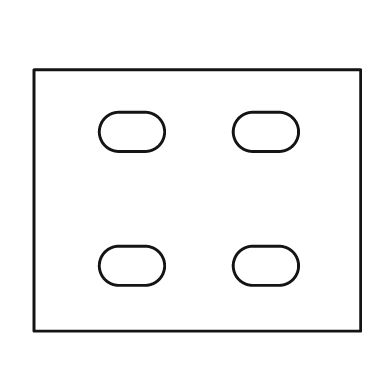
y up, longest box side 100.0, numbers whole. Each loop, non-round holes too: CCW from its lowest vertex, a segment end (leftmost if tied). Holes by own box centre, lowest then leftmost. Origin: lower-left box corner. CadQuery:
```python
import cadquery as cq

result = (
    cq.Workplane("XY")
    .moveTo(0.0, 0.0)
    .lineTo(100.0, 0.0)
    .lineTo(100.0, 80.0)
    .lineTo(0.0, 80.0)
    .close()
    .moveTo(26.0, 14.0)
    .lineTo(34.0, 14.0)
    .threePointArc((40.0, 20.0), (34.0, 26.0))
    .lineTo(26.0, 26.0)
    .threePointArc((20.0, 20.0), (26.0, 14.0))
    .close()
    .moveTo(67.0, 14.0)
    .lineTo(75.0, 14.0)
    .threePointArc((81.0, 20.0), (75.0, 26.0))
    .lineTo(67.0, 26.0)
    .threePointArc((61.0, 20.0), (67.0, 14.0))
    .close()
    .moveTo(26.0, 55.0)
    .lineTo(34.0, 55.0)
    .threePointArc((40.0, 61.0), (34.0, 67.0))
    .lineTo(26.0, 67.0)
    .threePointArc((20.0, 61.0), (26.0, 55.0))
    .close()
    .moveTo(67.0, 55.0)
    .lineTo(75.0, 55.0)
    .threePointArc((81.0, 61.0), (75.0, 67.0))
    .lineTo(67.0, 67.0)
    .threePointArc((61.0, 61.0), (67.0, 55.0))
    .close()
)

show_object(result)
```